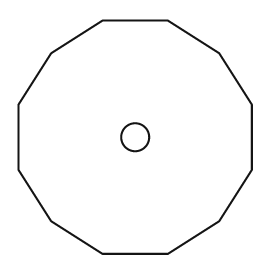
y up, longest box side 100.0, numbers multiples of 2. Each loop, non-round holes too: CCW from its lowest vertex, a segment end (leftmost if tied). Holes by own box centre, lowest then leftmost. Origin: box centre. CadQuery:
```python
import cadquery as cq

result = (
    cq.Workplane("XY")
    .moveTo(-14.0, -50.0)
    .lineTo(14.0, -50.0)
    .lineTo(36.0, -36.0)
    .lineTo(50.0, -14.0)
    .lineTo(50.0, 14.0)
    .lineTo(36.0, 36.0)
    .lineTo(14.0, 50.0)
    .lineTo(-14.0, 50.0)
    .lineTo(-36.0, 36.0)
    .lineTo(-50.0, 14.0)
    .lineTo(-50.0, -14.0)
    .lineTo(-36.0, -36.0)
    .close()
    .moveTo(0.0, 0.0)
    .circle(6.0)
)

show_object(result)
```